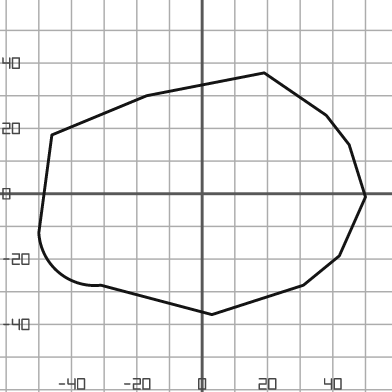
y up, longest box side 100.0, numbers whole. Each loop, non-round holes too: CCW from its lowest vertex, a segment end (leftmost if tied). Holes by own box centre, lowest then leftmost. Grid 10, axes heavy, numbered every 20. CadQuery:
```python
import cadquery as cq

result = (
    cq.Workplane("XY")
    .moveTo(3.0, -37.0)
    .lineTo(31.0, -28.0)
    .lineTo(42.0, -19.0)
    .lineTo(50.0, -1.0)
    .lineTo(45.0, 15.0)
    .lineTo(38.0, 24.0)
    .lineTo(19.0, 37.0)
    .lineTo(-17.0, 30.0)
    .lineTo(-46.0, 18.0)
    .lineTo(-50.0, -12.0)
    .threePointArc((-44.0, -24.0), (-31.0, -28.0))
    .close()
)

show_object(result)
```